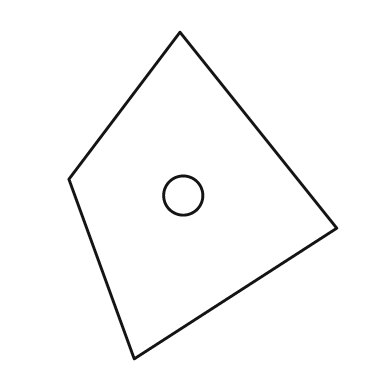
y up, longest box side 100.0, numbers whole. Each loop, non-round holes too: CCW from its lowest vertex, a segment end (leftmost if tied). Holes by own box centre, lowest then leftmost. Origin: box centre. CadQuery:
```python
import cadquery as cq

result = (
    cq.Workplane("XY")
    .moveTo(-21.0, -50.0)
    .lineTo(41.0, -10.0)
    .lineTo(-7.0, 50.0)
    .lineTo(-41.0, 5.0)
    .close()
    .moveTo(-6.0, 0.0)
    .circle(6.0)
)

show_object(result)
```